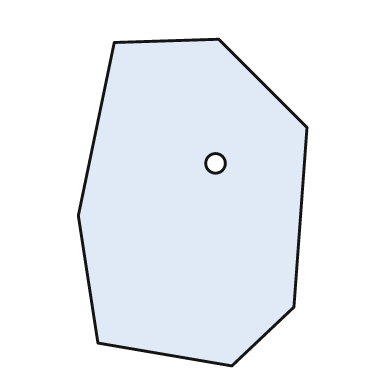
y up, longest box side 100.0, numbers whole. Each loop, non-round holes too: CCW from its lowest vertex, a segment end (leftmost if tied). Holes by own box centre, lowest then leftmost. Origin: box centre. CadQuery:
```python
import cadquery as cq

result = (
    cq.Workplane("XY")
    .moveTo(12.0, -50.0)
    .lineTo(31.0, -32.0)
    .lineTo(35.0, 23.0)
    .lineTo(8.0, 50.0)
    .lineTo(-24.0, 49.0)
    .lineTo(-35.0, -4.0)
    .lineTo(-29.0, -43.0)
    .close()
    .moveTo(7.0, 12.0)
    .circle(3.0)
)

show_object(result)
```